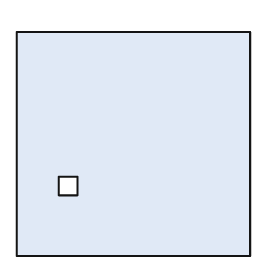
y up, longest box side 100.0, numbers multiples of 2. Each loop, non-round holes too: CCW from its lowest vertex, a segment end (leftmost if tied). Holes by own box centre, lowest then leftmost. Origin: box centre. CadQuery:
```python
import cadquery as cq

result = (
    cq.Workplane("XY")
    .moveTo(-50.0, -48.0)
    .lineTo(50.0, -48.0)
    .lineTo(50.0, 48.0)
    .lineTo(-50.0, 48.0)
    .close()
    .moveTo(-32.0, -22.0)
    .lineTo(-24.0, -22.0)
    .lineTo(-24.0, -14.0)
    .lineTo(-32.0, -14.0)
    .close()
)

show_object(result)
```